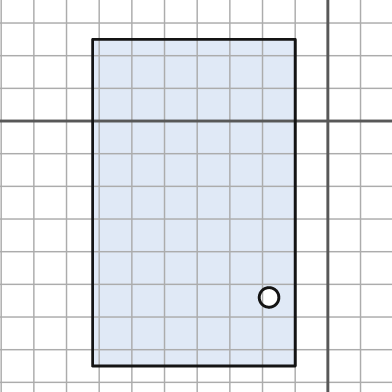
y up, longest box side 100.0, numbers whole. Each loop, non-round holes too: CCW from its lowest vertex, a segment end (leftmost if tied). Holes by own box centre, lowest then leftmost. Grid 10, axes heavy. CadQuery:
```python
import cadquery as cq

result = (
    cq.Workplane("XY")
    .moveTo(-72.0, -75.0)
    .lineTo(-10.0, -75.0)
    .lineTo(-10.0, 25.0)
    .lineTo(-72.0, 25.0)
    .close()
    .moveTo(-18.0, -54.0)
    .circle(3.0)
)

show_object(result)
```